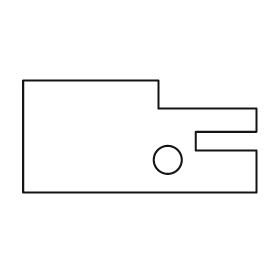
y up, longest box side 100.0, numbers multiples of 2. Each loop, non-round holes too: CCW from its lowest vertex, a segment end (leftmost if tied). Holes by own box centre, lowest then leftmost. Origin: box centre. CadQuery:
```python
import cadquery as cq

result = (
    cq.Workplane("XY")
    .moveTo(-50.0, -24.0)
    .lineTo(50.0, -24.0)
    .lineTo(50.0, -6.0)
    .lineTo(24.0, -6.0)
    .lineTo(24.0, 2.0)
    .lineTo(50.0, 2.0)
    .lineTo(50.0, 12.0)
    .lineTo(8.0, 12.0)
    .lineTo(8.0, 24.0)
    .lineTo(-50.0, 24.0)
    .close()
    .moveTo(12.0, -10.0)
    .circle(6.0)
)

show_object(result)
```